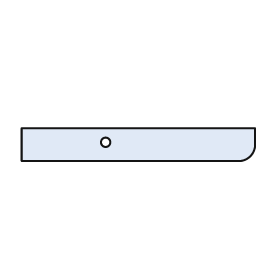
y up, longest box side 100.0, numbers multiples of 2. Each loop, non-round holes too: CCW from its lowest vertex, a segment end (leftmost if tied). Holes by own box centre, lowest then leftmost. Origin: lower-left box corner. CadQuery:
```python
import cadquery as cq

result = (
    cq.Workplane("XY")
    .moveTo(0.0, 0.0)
    .lineTo(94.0, 0.0)
    .threePointArc((98.0, 2.0), (100.0, 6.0))
    .lineTo(100.0, 14.0)
    .lineTo(0.0, 14.0)
    .close()
    .moveTo(36.0, 8.0)
    .circle(2.0)
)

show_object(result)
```